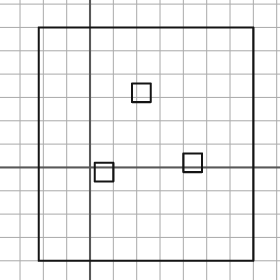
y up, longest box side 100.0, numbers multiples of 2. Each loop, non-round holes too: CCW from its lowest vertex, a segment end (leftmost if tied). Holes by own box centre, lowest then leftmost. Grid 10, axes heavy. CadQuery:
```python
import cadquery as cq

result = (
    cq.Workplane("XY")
    .moveTo(-22.0, -40.0)
    .lineTo(70.0, -40.0)
    .lineTo(70.0, 60.0)
    .lineTo(-22.0, 60.0)
    .close()
    .moveTo(2.0, -6.0)
    .lineTo(10.0, -6.0)
    .lineTo(10.0, 2.0)
    .lineTo(2.0, 2.0)
    .close()
    .moveTo(40.0, -2.0)
    .lineTo(48.0, -2.0)
    .lineTo(48.0, 6.0)
    .lineTo(40.0, 6.0)
    .close()
    .moveTo(18.0, 28.0)
    .lineTo(26.0, 28.0)
    .lineTo(26.0, 36.0)
    .lineTo(18.0, 36.0)
    .close()
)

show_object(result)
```